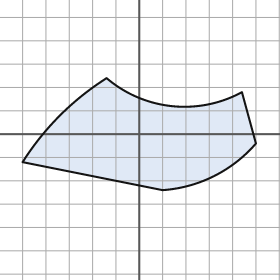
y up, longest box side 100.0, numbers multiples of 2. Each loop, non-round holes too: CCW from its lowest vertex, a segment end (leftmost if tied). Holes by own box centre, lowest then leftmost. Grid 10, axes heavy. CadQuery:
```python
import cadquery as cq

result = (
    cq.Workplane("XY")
    .moveTo(10.0, -24.0)
    .threePointArc((32.0, -18.0), (50.0, -4.0))
    .lineTo(44.0, 18.0)
    .threePointArc((14.0, 12.0), (-14.0, 24.0))
    .threePointArc((-34.0, 8.0), (-50.0, -12.0))
    .close()
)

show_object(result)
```